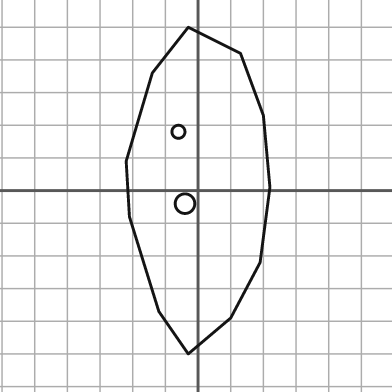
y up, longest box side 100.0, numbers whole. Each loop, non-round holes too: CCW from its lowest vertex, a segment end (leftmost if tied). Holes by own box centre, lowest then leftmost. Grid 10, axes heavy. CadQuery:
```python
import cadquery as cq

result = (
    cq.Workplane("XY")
    .moveTo(-3.0, -50.0)
    .lineTo(10.0, -39.0)
    .lineTo(19.0, -22.0)
    .lineTo(22.0, 1.0)
    .lineTo(20.0, 23.0)
    .lineTo(13.0, 42.0)
    .lineTo(-3.0, 50.0)
    .lineTo(-14.0, 36.0)
    .lineTo(-22.0, 9.0)
    .lineTo(-21.0, -8.0)
    .lineTo(-12.0, -37.0)
    .close()
    .moveTo(-4.0, -4.0)
    .circle(3.0)
    .moveTo(-6.0, 18.0)
    .circle(2.0)
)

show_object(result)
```